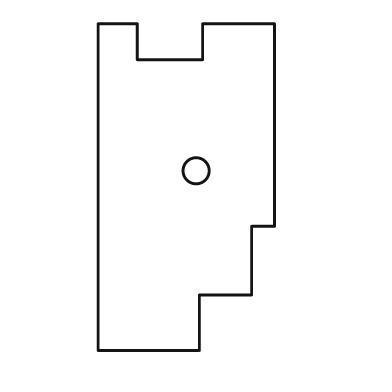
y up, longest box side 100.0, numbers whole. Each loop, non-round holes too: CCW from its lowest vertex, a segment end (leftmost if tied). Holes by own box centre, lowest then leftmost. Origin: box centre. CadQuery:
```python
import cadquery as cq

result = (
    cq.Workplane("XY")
    .moveTo(-27.0, -50.0)
    .lineTo(4.0, -50.0)
    .lineTo(4.0, -33.0)
    .lineTo(20.0, -33.0)
    .lineTo(20.0, -12.0)
    .lineTo(27.0, -12.0)
    .lineTo(27.0, 50.0)
    .lineTo(5.0, 50.0)
    .lineTo(5.0, 39.0)
    .lineTo(-15.0, 39.0)
    .lineTo(-15.0, 50.0)
    .lineTo(-27.0, 50.0)
    .close()
    .moveTo(3.0, 5.0)
    .circle(4.0)
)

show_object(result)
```